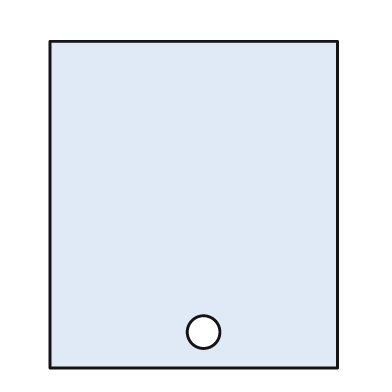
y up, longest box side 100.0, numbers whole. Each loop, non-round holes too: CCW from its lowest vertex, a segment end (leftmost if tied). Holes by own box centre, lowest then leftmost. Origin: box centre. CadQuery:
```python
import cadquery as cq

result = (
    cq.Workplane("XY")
    .moveTo(-44.0, -50.0)
    .lineTo(44.0, -50.0)
    .lineTo(44.0, 50.0)
    .lineTo(-44.0, 50.0)
    .close()
    .moveTo(3.0, -39.0)
    .circle(5.0)
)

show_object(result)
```